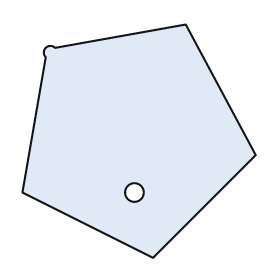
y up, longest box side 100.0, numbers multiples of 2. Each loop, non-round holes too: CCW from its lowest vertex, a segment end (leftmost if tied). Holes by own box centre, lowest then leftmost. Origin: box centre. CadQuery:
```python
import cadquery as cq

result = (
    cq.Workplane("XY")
    .moveTo(6.0, -50.0)
    .lineTo(50.0, -6.0)
    .lineTo(20.0, 50.0)
    .lineTo(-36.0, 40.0)
    .threePointArc((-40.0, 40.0), (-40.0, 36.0))
    .lineTo(-50.0, -22.0)
    .close()
    .moveTo(-2.0, -22.0)
    .circle(4.0)
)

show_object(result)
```